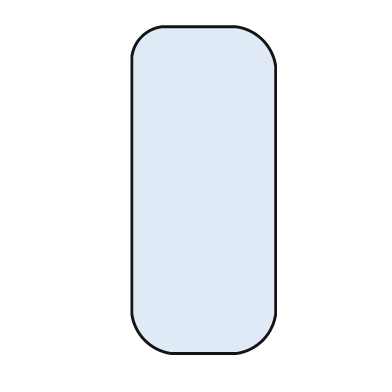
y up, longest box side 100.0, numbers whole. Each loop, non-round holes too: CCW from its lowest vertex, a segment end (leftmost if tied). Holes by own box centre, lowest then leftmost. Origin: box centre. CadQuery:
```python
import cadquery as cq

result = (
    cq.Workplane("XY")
    .moveTo(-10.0, -50.0)
    .lineTo(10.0, -50.0)
    .threePointArc((18.0, -46.0), (22.0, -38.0))
    .lineTo(22.0, 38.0)
    .threePointArc((18.0, 46.0), (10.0, 50.0))
    .lineTo(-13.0, 50.0)
    .threePointArc((-19.0, 47.0), (-22.0, 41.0))
    .lineTo(-22.0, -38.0)
    .threePointArc((-18.0, -46.0), (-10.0, -50.0))
    .close()
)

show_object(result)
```